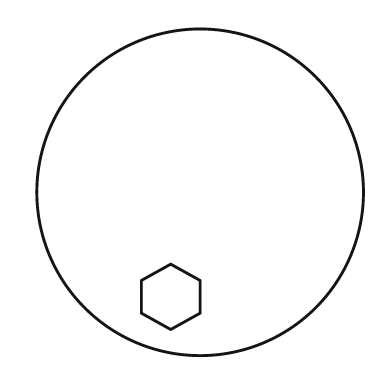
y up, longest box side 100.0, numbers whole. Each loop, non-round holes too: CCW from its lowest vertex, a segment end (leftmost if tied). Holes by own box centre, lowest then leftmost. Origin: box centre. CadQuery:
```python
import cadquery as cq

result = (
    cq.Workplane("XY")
    .moveTo(0.0, 0.0)
    .circle(50.0)
    .moveTo(-9.0, -42.0)
    .lineTo(0.0, -37.0)
    .lineTo(0.0, -27.0)
    .lineTo(-9.0, -22.0)
    .lineTo(-18.0, -27.0)
    .lineTo(-18.0, -37.0)
    .close()
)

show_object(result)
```